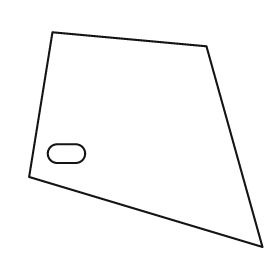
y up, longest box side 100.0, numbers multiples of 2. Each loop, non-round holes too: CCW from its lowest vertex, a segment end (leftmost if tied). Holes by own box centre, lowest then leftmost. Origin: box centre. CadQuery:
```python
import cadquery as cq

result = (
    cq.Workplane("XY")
    .moveTo(50.0, -46.0)
    .lineTo(26.0, 40.0)
    .lineTo(-40.0, 46.0)
    .lineTo(-50.0, -16.0)
    .close()
    .moveTo(-38.0, -10.0)
    .lineTo(-30.0, -10.0)
    .threePointArc((-26.0, -6.0), (-30.0, -2.0))
    .lineTo(-38.0, -2.0)
    .threePointArc((-42.0, -6.0), (-38.0, -10.0))
    .close()
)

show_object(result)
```